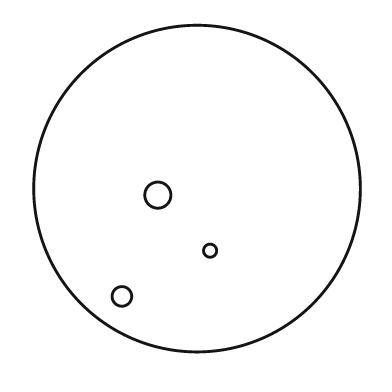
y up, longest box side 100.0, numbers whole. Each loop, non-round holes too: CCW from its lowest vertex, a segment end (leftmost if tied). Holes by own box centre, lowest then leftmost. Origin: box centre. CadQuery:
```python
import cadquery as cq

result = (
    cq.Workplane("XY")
    .moveTo(0.0, 0.0)
    .circle(50.0)
    .moveTo(-23.0, -33.0)
    .circle(3.0)
    .moveTo(4.0, -19.0)
    .circle(2.0)
    .moveTo(-12.0, -2.0)
    .circle(4.0)
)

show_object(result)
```